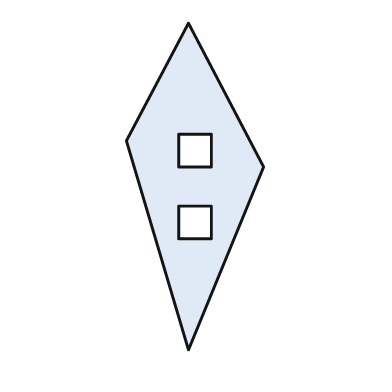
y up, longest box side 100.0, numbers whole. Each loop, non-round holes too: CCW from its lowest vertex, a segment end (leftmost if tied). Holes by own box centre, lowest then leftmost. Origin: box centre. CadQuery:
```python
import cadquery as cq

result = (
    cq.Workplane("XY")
    .moveTo(-2.0, -50.0)
    .lineTo(21.0, 6.0)
    .lineTo(-2.0, 50.0)
    .lineTo(-21.0, 14.0)
    .close()
    .moveTo(-5.0, -16.0)
    .lineTo(5.0, -16.0)
    .lineTo(5.0, -6.0)
    .lineTo(-5.0, -6.0)
    .close()
    .moveTo(-5.0, 6.0)
    .lineTo(5.0, 6.0)
    .lineTo(5.0, 16.0)
    .lineTo(-5.0, 16.0)
    .close()
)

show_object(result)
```